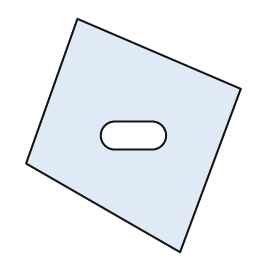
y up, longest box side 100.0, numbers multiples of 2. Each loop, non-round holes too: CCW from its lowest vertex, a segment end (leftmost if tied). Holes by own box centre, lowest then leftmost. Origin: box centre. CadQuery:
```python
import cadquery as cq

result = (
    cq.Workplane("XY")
    .moveTo(20.0, -50.0)
    .lineTo(46.0, 20.0)
    .lineTo(-24.0, 50.0)
    .lineTo(-46.0, -12.0)
    .close()
    .moveTo(-8.0, -6.0)
    .lineTo(8.0, -6.0)
    .threePointArc((14.0, 0.0), (8.0, 6.0))
    .lineTo(-8.0, 6.0)
    .threePointArc((-14.0, 0.0), (-8.0, -6.0))
    .close()
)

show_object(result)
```